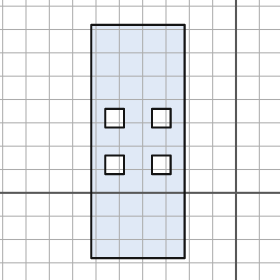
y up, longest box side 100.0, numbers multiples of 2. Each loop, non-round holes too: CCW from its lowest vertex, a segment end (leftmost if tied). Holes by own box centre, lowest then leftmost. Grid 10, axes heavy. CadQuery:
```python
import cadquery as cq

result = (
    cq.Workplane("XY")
    .moveTo(-62.0, -28.0)
    .lineTo(-22.0, -28.0)
    .lineTo(-22.0, 72.0)
    .lineTo(-62.0, 72.0)
    .close()
    .moveTo(-56.0, 8.0)
    .lineTo(-48.0, 8.0)
    .lineTo(-48.0, 16.0)
    .lineTo(-56.0, 16.0)
    .close()
    .moveTo(-36.0, 8.0)
    .lineTo(-28.0, 8.0)
    .lineTo(-28.0, 16.0)
    .lineTo(-36.0, 16.0)
    .close()
    .moveTo(-56.0, 28.0)
    .lineTo(-48.0, 28.0)
    .lineTo(-48.0, 36.0)
    .lineTo(-56.0, 36.0)
    .close()
    .moveTo(-36.0, 28.0)
    .lineTo(-28.0, 28.0)
    .lineTo(-28.0, 36.0)
    .lineTo(-36.0, 36.0)
    .close()
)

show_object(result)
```